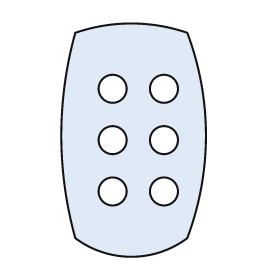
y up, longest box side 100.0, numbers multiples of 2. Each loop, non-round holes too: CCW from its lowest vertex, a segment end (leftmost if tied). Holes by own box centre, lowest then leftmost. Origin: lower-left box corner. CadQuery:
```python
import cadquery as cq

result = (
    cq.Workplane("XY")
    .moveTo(6.0, 8.0)
    .threePointArc((30.0, 0.0), (54.0, 8.0))
    .threePointArc((62.0, 52.0), (54.0, 96.0))
    .threePointArc((30.0, 100.0), (6.0, 96.0))
    .threePointArc((0.0, 52.0), (6.0, 8.0))
    .close()
    .moveTo(22.0, 28.0)
    .circle(6.0)
    .moveTo(44.0, 28.0)
    .circle(6.0)
    .moveTo(22.0, 50.0)
    .circle(6.0)
    .moveTo(44.0, 50.0)
    .circle(6.0)
    .moveTo(22.0, 72.0)
    .circle(6.0)
    .moveTo(44.0, 72.0)
    .circle(6.0)
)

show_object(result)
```